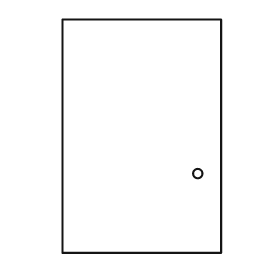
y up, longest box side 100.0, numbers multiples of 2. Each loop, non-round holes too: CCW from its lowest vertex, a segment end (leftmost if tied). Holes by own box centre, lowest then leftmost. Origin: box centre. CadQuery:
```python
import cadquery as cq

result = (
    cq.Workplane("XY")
    .moveTo(-34.0, -50.0)
    .lineTo(34.0, -50.0)
    .lineTo(34.0, 50.0)
    .lineTo(-34.0, 50.0)
    .close()
    .moveTo(24.0, -16.0)
    .circle(2.0)
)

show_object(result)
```